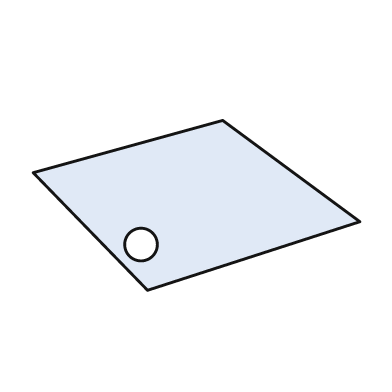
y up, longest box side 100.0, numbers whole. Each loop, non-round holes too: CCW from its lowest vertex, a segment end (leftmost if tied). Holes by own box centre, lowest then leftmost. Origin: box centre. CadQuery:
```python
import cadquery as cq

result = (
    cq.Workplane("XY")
    .moveTo(-15.0, -26.0)
    .lineTo(50.0, -5.0)
    .lineTo(8.0, 26.0)
    .lineTo(-50.0, 10.0)
    .close()
    .moveTo(-17.0, -12.0)
    .circle(5.0)
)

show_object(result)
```